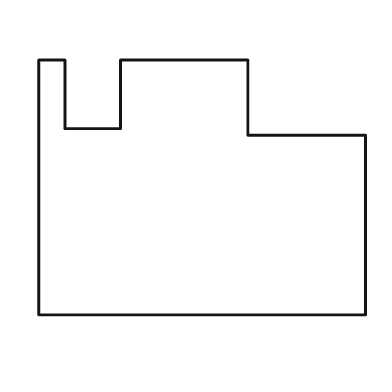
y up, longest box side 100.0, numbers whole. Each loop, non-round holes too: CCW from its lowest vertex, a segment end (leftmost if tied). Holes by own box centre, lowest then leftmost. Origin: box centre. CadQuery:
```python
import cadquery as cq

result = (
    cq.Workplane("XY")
    .moveTo(-50.0, -39.0)
    .lineTo(50.0, -39.0)
    .lineTo(50.0, 16.0)
    .lineTo(14.0, 16.0)
    .lineTo(14.0, 39.0)
    .lineTo(-25.0, 39.0)
    .lineTo(-25.0, 18.0)
    .lineTo(-42.0, 18.0)
    .lineTo(-42.0, 39.0)
    .lineTo(-50.0, 39.0)
    .close()
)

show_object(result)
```